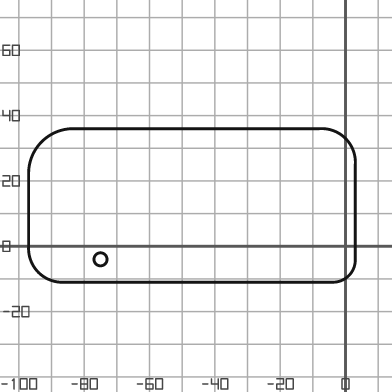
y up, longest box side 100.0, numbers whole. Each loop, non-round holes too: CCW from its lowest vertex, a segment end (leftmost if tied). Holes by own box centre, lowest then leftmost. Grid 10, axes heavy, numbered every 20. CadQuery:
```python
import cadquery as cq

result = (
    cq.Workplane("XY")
    .moveTo(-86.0, -11.0)
    .lineTo(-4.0, -11.0)
    .threePointArc((1.0, -9.0), (3.0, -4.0))
    .lineTo(3.0, 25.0)
    .threePointArc((0.0, 33.0), (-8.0, 36.0))
    .lineTo(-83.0, 36.0)
    .threePointArc((-93.0, 32.0), (-97.0, 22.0))
    .lineTo(-97.0, 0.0)
    .threePointArc((-94.0, -8.0), (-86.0, -11.0))
    .close()
    .moveTo(-75.0, -4.0)
    .circle(2.0)
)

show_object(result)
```